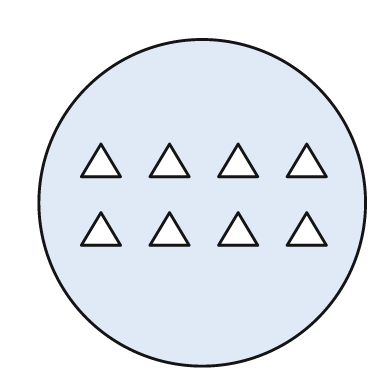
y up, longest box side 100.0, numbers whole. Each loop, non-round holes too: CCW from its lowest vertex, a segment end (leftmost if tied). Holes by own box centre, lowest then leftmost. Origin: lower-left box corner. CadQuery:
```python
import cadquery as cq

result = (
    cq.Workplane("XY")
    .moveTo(50.0, 50.0)
    .circle(50.0)
    .moveTo(13.0, 37.0)
    .lineTo(25.0, 37.0)
    .lineTo(19.0, 47.0)
    .close()
    .moveTo(34.0, 37.0)
    .lineTo(46.0, 37.0)
    .lineTo(40.0, 47.0)
    .close()
    .moveTo(55.0, 37.0)
    .lineTo(67.0, 37.0)
    .lineTo(61.0, 47.0)
    .close()
    .moveTo(76.0, 37.0)
    .lineTo(88.0, 37.0)
    .lineTo(82.0, 47.0)
    .close()
    .moveTo(13.0, 58.0)
    .lineTo(25.0, 58.0)
    .lineTo(19.0, 68.0)
    .close()
    .moveTo(34.0, 58.0)
    .lineTo(46.0, 58.0)
    .lineTo(40.0, 68.0)
    .close()
    .moveTo(55.0, 58.0)
    .lineTo(67.0, 58.0)
    .lineTo(61.0, 68.0)
    .close()
    .moveTo(76.0, 58.0)
    .lineTo(88.0, 58.0)
    .lineTo(82.0, 68.0)
    .close()
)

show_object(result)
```